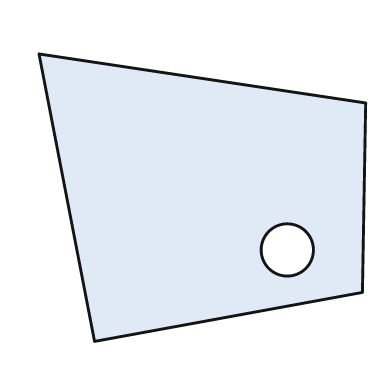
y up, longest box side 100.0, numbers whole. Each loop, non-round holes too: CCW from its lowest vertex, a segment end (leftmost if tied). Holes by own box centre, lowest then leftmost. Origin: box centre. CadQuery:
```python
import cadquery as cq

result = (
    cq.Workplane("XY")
    .moveTo(-33.0, -44.0)
    .lineTo(49.0, -29.0)
    .lineTo(50.0, 29.0)
    .lineTo(-50.0, 44.0)
    .close()
    .moveTo(26.0, -16.0)
    .circle(8.0)
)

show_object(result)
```